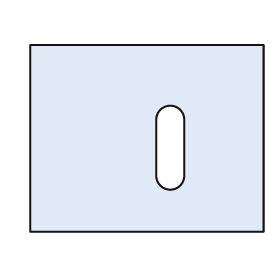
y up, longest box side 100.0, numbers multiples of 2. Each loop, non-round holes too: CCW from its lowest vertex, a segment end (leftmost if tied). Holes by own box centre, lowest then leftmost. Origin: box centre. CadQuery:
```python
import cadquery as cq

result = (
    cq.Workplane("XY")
    .moveTo(-50.0, -40.0)
    .lineTo(50.0, -40.0)
    .lineTo(50.0, 40.0)
    .lineTo(-50.0, 40.0)
    .close()
    .moveTo(4.0, -16.0)
    .threePointArc((10.0, -22.0), (16.0, -16.0))
    .lineTo(16.0, 8.0)
    .threePointArc((10.0, 14.0), (4.0, 8.0))
    .close()
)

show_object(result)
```